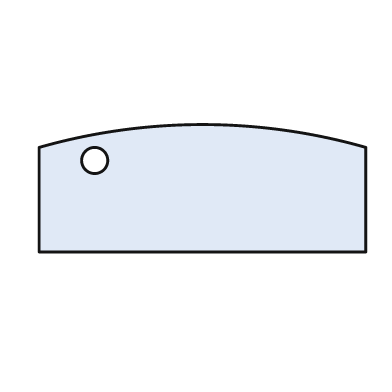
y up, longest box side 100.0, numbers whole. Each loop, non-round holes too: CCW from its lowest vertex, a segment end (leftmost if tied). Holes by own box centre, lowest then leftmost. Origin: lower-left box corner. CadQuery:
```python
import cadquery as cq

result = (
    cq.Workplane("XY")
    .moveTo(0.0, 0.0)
    .lineTo(100.0, 0.0)
    .lineTo(100.0, 32.0)
    .threePointArc((50.0, 39.0), (0.0, 32.0))
    .close()
    .moveTo(17.0, 28.0)
    .circle(4.0)
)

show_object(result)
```